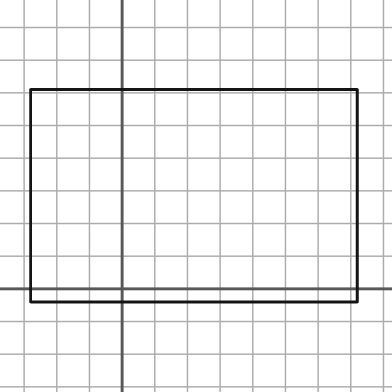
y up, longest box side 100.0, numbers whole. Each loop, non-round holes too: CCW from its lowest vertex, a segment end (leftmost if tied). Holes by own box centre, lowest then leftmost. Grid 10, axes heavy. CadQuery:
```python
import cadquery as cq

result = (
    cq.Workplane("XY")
    .moveTo(-28.0, -4.0)
    .lineTo(72.0, -4.0)
    .lineTo(72.0, 61.0)
    .lineTo(-28.0, 61.0)
    .close()
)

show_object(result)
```